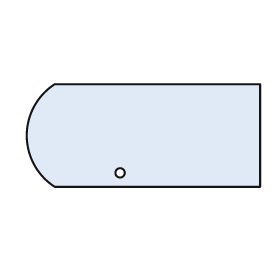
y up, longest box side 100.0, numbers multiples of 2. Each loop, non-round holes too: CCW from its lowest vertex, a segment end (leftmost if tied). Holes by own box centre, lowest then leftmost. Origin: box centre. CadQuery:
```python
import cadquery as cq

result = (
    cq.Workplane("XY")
    .moveTo(-38.0, -22.0)
    .lineTo(50.0, -22.0)
    .lineTo(50.0, 22.0)
    .lineTo(-38.0, 22.0)
    .threePointArc((-50.0, 0.0), (-38.0, -22.0))
    .close()
    .moveTo(-10.0, -16.0)
    .circle(2.0)
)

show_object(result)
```